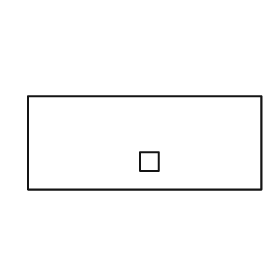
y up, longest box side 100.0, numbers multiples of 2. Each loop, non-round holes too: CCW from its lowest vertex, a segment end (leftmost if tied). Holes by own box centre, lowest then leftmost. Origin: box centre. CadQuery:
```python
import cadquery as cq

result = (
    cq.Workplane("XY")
    .moveTo(-50.0, -20.0)
    .lineTo(50.0, -20.0)
    .lineTo(50.0, 20.0)
    .lineTo(-50.0, 20.0)
    .close()
    .moveTo(-2.0, -12.0)
    .lineTo(6.0, -12.0)
    .lineTo(6.0, -4.0)
    .lineTo(-2.0, -4.0)
    .close()
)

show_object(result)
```